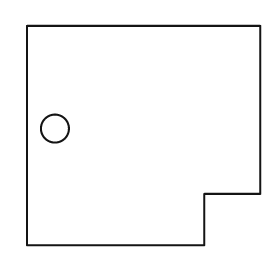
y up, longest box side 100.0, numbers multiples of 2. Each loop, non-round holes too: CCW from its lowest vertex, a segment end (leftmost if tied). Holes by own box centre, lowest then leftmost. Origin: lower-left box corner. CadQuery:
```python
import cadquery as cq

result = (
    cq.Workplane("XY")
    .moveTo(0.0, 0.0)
    .lineTo(76.0, 0.0)
    .lineTo(76.0, 22.0)
    .lineTo(100.0, 22.0)
    .lineTo(100.0, 94.0)
    .lineTo(0.0, 94.0)
    .close()
    .moveTo(12.0, 50.0)
    .circle(6.0)
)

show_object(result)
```